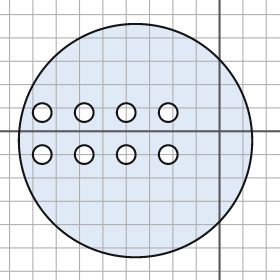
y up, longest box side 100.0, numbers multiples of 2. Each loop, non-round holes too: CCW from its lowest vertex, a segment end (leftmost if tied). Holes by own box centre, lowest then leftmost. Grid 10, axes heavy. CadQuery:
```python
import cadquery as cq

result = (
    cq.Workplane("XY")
    .moveTo(-36.0, -4.0)
    .circle(50.0)
    .moveTo(-76.0, -10.0)
    .circle(4.0)
    .moveTo(-58.0, -10.0)
    .circle(4.0)
    .moveTo(-40.0, -10.0)
    .circle(4.0)
    .moveTo(-22.0, -10.0)
    .circle(4.0)
    .moveTo(-76.0, 8.0)
    .circle(4.0)
    .moveTo(-58.0, 8.0)
    .circle(4.0)
    .moveTo(-40.0, 8.0)
    .circle(4.0)
    .moveTo(-22.0, 8.0)
    .circle(4.0)
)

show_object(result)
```